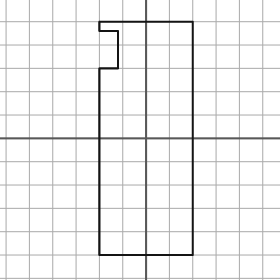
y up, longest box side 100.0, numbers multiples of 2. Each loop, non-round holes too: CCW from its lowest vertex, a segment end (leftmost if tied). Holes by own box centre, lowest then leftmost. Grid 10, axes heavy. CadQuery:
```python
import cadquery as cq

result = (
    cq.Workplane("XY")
    .moveTo(-20.0, -50.0)
    .lineTo(20.0, -50.0)
    .lineTo(20.0, 50.0)
    .lineTo(-20.0, 50.0)
    .lineTo(-20.0, 46.0)
    .lineTo(-12.0, 46.0)
    .lineTo(-12.0, 30.0)
    .lineTo(-20.0, 30.0)
    .close()
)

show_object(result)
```